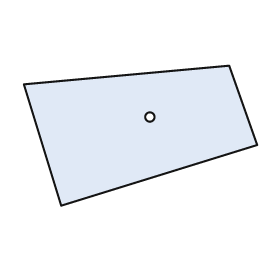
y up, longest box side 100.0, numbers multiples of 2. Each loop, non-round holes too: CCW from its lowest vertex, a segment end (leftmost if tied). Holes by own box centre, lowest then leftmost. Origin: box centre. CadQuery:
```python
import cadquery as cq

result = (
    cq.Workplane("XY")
    .moveTo(-34.0, -30.0)
    .lineTo(50.0, -4.0)
    .lineTo(38.0, 30.0)
    .lineTo(-50.0, 22.0)
    .close()
    .moveTo(4.0, 8.0)
    .circle(2.0)
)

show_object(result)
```